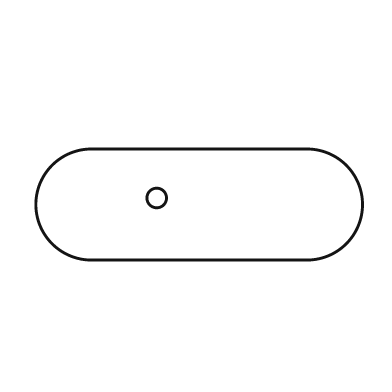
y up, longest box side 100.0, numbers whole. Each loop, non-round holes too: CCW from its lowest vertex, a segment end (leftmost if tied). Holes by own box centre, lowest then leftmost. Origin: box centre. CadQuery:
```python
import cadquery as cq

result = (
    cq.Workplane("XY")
    .moveTo(-33.0, -17.0)
    .lineTo(33.0, -17.0)
    .threePointArc((50.0, 0.0), (33.0, 17.0))
    .lineTo(-33.0, 17.0)
    .threePointArc((-50.0, 0.0), (-33.0, -17.0))
    .close()
    .moveTo(-13.0, 2.0)
    .circle(3.0)
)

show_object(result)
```